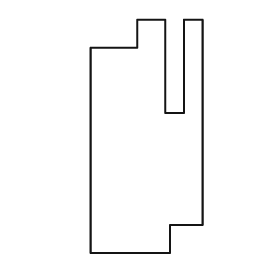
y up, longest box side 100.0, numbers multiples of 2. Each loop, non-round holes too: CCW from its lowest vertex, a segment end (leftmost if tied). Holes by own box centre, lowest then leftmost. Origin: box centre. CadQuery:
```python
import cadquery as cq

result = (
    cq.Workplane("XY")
    .moveTo(-24.0, -50.0)
    .lineTo(10.0, -50.0)
    .lineTo(10.0, -38.0)
    .lineTo(24.0, -38.0)
    .lineTo(24.0, 50.0)
    .lineTo(16.0, 50.0)
    .lineTo(16.0, 10.0)
    .lineTo(8.0, 10.0)
    .lineTo(8.0, 50.0)
    .lineTo(-4.0, 50.0)
    .lineTo(-4.0, 38.0)
    .lineTo(-24.0, 38.0)
    .close()
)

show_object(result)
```